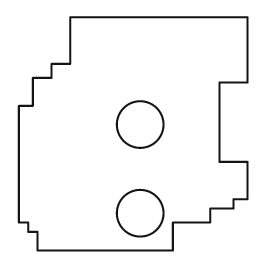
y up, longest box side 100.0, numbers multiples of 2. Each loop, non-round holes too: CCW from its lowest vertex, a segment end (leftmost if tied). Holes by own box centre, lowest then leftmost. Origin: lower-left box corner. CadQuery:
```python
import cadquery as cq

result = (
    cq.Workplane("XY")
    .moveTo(8.0, 0.0)
    .lineTo(66.0, 0.0)
    .lineTo(66.0, 12.0)
    .lineTo(82.0, 12.0)
    .lineTo(82.0, 18.0)
    .lineTo(92.0, 18.0)
    .lineTo(92.0, 22.0)
    .lineTo(98.0, 22.0)
    .lineTo(98.0, 38.0)
    .lineTo(86.0, 38.0)
    .lineTo(86.0, 72.0)
    .lineTo(98.0, 72.0)
    .lineTo(98.0, 100.0)
    .lineTo(22.0, 100.0)
    .lineTo(22.0, 80.0)
    .lineTo(14.0, 80.0)
    .lineTo(14.0, 74.0)
    .lineTo(6.0, 74.0)
    .lineTo(6.0, 62.0)
    .lineTo(0.0, 62.0)
    .lineTo(0.0, 12.0)
    .lineTo(4.0, 12.0)
    .lineTo(4.0, 8.0)
    .lineTo(8.0, 8.0)
    .close()
    .moveTo(52.0, 16.0)
    .circle(10.0)
    .moveTo(52.0, 54.0)
    .circle(10.0)
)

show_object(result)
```